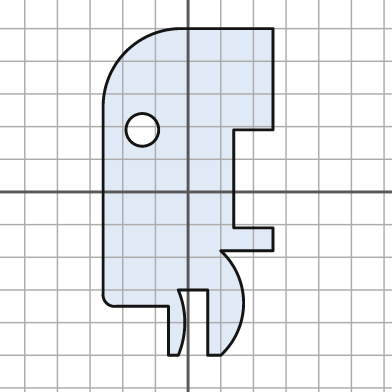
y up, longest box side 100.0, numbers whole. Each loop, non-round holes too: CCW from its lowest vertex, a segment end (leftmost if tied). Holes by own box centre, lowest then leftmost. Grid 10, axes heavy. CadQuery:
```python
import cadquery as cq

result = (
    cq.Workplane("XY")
    .moveTo(-6.0, -50.0)
    .lineTo(-3.0, -50.0)
    .threePointArc((-1.0, -40.0), (-3.0, -30.0))
    .lineTo(6.0, -30.0)
    .lineTo(6.0, -50.0)
    .lineTo(10.0, -50.0)
    .threePointArc((17.0, -34.0), (10.0, -18.0))
    .lineTo(26.0, -18.0)
    .lineTo(26.0, -11.0)
    .lineTo(14.0, -11.0)
    .lineTo(14.0, 19.0)
    .lineTo(26.0, 19.0)
    .lineTo(26.0, 50.0)
    .lineTo(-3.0, 50.0)
    .threePointArc((-19.0, 43.0), (-26.0, 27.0))
    .lineTo(-26.0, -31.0)
    .threePointArc((-25.0, -34.0), (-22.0, -35.0))
    .lineTo(-6.0, -35.0)
    .close()
    .moveTo(-14.0, 19.0)
    .circle(5.0)
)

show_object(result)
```